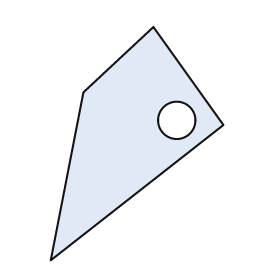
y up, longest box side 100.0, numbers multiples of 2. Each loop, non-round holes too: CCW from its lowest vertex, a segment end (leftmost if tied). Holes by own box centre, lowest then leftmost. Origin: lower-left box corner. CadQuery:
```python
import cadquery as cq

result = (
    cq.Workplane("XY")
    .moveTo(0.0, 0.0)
    .lineTo(74.0, 58.0)
    .lineTo(44.0, 100.0)
    .lineTo(14.0, 72.0)
    .close()
    .moveTo(54.0, 60.0)
    .circle(8.0)
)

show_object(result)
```